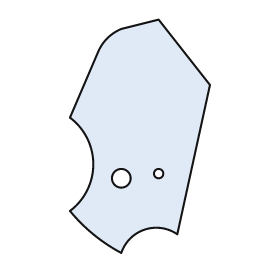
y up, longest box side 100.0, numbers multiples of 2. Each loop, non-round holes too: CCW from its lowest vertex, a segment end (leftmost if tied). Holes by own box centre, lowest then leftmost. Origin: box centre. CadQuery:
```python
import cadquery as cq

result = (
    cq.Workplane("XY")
    .moveTo(-8.0, -50.0)
    .threePointArc((2.0, -40.0), (16.0, -42.0))
    .lineTo(30.0, 22.0)
    .lineTo(8.0, 50.0)
    .lineTo(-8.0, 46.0)
    .threePointArc((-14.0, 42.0), (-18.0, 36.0))
    .lineTo(-30.0, 8.0)
    .threePointArc((-20.0, -12.0), (-30.0, -32.0))
    .threePointArc((-20.0, -42.0), (-8.0, -50.0))
    .close()
    .moveTo(-8.0, -18.0)
    .circle(4.0)
    .moveTo(8.0, -16.0)
    .circle(2.0)
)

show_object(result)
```